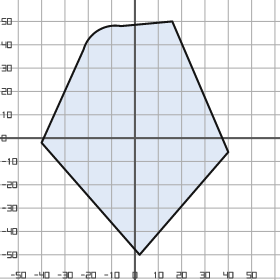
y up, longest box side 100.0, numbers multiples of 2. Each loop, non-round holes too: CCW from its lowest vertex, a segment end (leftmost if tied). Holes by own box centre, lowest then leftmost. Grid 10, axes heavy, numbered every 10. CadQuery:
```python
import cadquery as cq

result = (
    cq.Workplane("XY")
    .moveTo(2.0, -50.0)
    .lineTo(40.0, -6.0)
    .lineTo(16.0, 50.0)
    .lineTo(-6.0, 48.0)
    .threePointArc((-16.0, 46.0), (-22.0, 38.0))
    .lineTo(-40.0, -2.0)
    .close()
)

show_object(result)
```